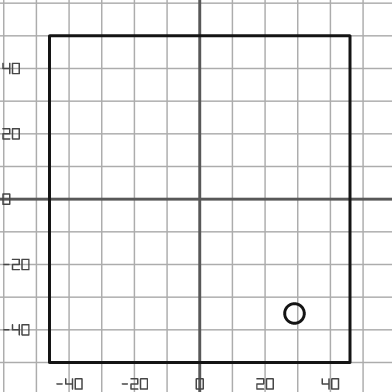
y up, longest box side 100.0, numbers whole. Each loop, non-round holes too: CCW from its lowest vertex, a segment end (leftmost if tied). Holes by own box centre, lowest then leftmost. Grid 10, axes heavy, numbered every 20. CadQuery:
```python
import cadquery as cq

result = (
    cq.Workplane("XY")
    .moveTo(-46.0, -50.0)
    .lineTo(46.0, -50.0)
    .lineTo(46.0, 50.0)
    .lineTo(-46.0, 50.0)
    .close()
    .moveTo(29.0, -35.0)
    .circle(3.0)
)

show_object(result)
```